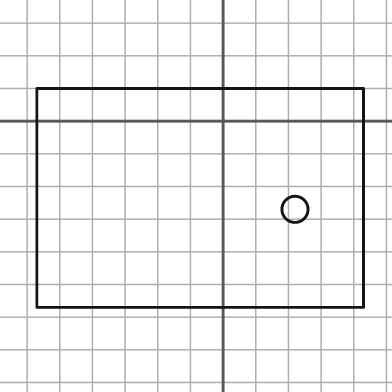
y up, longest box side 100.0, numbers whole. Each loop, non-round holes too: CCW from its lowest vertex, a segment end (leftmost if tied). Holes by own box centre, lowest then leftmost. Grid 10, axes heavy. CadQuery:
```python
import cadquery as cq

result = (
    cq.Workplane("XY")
    .moveTo(-57.0, -57.0)
    .lineTo(43.0, -57.0)
    .lineTo(43.0, 10.0)
    .lineTo(-57.0, 10.0)
    .close()
    .moveTo(22.0, -27.0)
    .circle(4.0)
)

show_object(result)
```